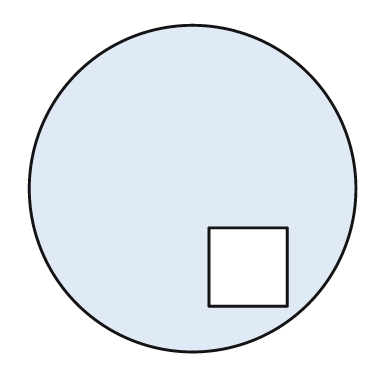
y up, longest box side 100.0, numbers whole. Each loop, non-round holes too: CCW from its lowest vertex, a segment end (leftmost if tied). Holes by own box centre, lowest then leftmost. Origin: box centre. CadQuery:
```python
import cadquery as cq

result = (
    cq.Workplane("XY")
    .moveTo(0.0, 0.0)
    .circle(50.0)
    .moveTo(5.0, -36.0)
    .lineTo(29.0, -36.0)
    .lineTo(29.0, -12.0)
    .lineTo(5.0, -12.0)
    .close()
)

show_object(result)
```